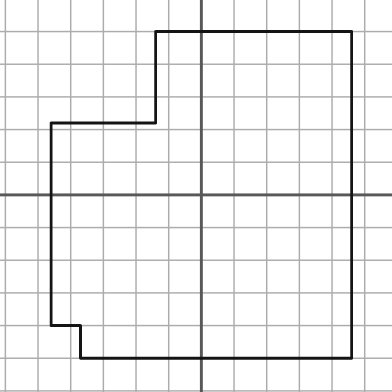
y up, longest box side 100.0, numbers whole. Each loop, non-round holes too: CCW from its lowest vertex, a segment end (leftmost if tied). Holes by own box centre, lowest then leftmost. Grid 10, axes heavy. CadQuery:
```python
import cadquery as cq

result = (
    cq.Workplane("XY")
    .moveTo(-37.0, -50.0)
    .lineTo(46.0, -50.0)
    .lineTo(46.0, 50.0)
    .lineTo(-14.0, 50.0)
    .lineTo(-14.0, 22.0)
    .lineTo(-46.0, 22.0)
    .lineTo(-46.0, -40.0)
    .lineTo(-37.0, -40.0)
    .close()
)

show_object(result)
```